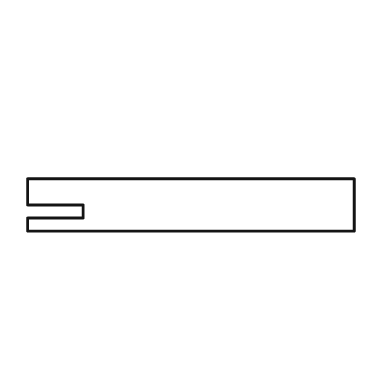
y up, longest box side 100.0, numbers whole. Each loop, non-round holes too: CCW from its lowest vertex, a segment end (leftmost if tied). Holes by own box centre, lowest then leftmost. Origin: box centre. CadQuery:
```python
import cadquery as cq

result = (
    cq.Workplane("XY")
    .moveTo(-50.0, -8.0)
    .lineTo(50.0, -8.0)
    .lineTo(50.0, 8.0)
    .lineTo(-50.0, 8.0)
    .lineTo(-50.0, 0.0)
    .lineTo(-33.0, 0.0)
    .lineTo(-33.0, -4.0)
    .lineTo(-50.0, -4.0)
    .close()
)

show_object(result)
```